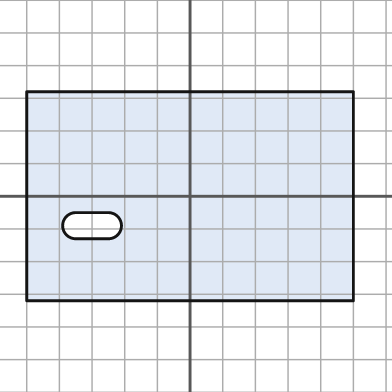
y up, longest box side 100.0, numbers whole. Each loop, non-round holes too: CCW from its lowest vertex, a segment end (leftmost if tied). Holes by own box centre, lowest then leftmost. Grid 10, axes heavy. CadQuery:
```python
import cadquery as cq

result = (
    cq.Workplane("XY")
    .moveTo(-50.0, -32.0)
    .lineTo(50.0, -32.0)
    .lineTo(50.0, 32.0)
    .lineTo(-50.0, 32.0)
    .close()
    .moveTo(-35.0, -13.0)
    .lineTo(-25.0, -13.0)
    .threePointArc((-21.0, -9.0), (-25.0, -5.0))
    .lineTo(-35.0, -5.0)
    .threePointArc((-39.0, -9.0), (-35.0, -13.0))
    .close()
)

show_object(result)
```